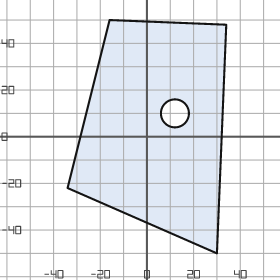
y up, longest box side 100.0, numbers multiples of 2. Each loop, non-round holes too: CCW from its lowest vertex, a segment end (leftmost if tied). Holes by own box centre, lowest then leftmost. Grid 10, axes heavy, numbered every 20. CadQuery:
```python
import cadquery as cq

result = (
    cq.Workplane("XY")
    .moveTo(30.0, -50.0)
    .lineTo(34.0, 48.0)
    .lineTo(-16.0, 50.0)
    .lineTo(-34.0, -22.0)
    .close()
    .moveTo(12.0, 10.0)
    .circle(6.0)
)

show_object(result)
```